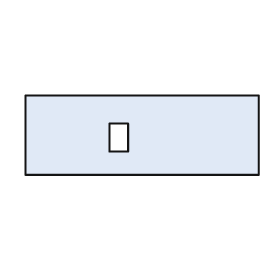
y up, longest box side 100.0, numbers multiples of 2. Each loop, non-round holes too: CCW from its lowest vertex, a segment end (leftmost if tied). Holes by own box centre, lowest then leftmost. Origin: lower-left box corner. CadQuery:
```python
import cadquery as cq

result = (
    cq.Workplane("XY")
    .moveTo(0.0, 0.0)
    .lineTo(100.0, 0.0)
    .lineTo(100.0, 34.0)
    .lineTo(0.0, 34.0)
    .close()
    .moveTo(36.0, 10.0)
    .lineTo(44.0, 10.0)
    .lineTo(44.0, 22.0)
    .lineTo(36.0, 22.0)
    .close()
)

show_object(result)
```